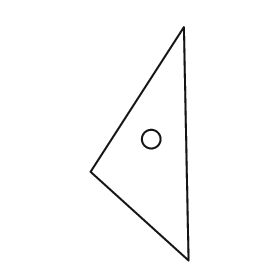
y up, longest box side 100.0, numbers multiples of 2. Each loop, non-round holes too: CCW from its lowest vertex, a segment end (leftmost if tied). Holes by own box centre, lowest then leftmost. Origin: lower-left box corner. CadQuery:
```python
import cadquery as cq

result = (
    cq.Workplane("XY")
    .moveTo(42.0, 0.0)
    .lineTo(40.0, 100.0)
    .lineTo(0.0, 38.0)
    .close()
    .moveTo(26.0, 52.0)
    .circle(4.0)
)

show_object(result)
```